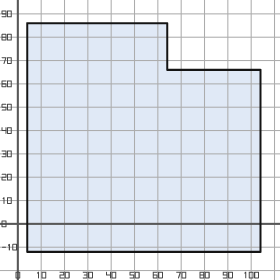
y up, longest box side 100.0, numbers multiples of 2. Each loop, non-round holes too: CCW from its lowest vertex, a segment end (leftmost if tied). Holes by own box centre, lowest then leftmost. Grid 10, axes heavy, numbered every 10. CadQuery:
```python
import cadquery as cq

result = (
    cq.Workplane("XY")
    .moveTo(4.0, -12.0)
    .lineTo(104.0, -12.0)
    .lineTo(104.0, 66.0)
    .lineTo(64.0, 66.0)
    .lineTo(64.0, 86.0)
    .lineTo(4.0, 86.0)
    .close()
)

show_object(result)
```